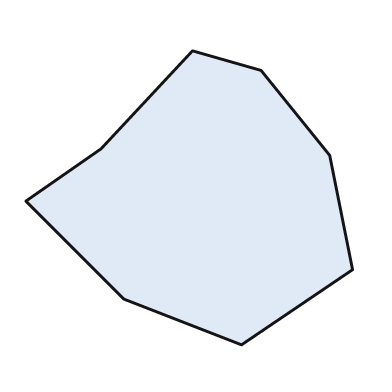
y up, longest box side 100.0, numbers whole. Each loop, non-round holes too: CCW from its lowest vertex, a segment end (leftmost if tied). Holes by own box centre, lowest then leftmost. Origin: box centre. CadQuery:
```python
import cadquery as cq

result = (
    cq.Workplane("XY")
    .moveTo(16.0, -45.0)
    .lineTo(50.0, -22.0)
    .lineTo(43.0, 13.0)
    .lineTo(22.0, 39.0)
    .lineTo(1.0, 45.0)
    .lineTo(-27.0, 15.0)
    .lineTo(-50.0, -1.0)
    .lineTo(-20.0, -31.0)
    .close()
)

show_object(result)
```